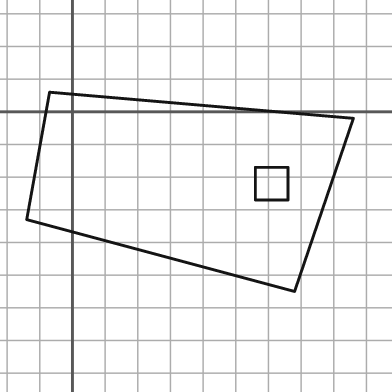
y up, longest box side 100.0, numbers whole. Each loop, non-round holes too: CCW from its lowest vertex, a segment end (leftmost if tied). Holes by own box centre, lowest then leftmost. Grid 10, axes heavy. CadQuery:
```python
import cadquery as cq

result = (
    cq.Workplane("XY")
    .moveTo(68.0, -55.0)
    .lineTo(86.0, -2.0)
    .lineTo(-7.0, 6.0)
    .lineTo(-14.0, -33.0)
    .close()
    .moveTo(56.0, -27.0)
    .lineTo(66.0, -27.0)
    .lineTo(66.0, -17.0)
    .lineTo(56.0, -17.0)
    .close()
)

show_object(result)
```